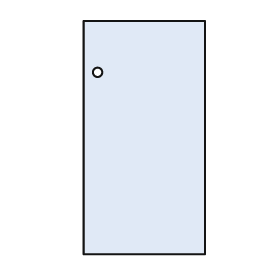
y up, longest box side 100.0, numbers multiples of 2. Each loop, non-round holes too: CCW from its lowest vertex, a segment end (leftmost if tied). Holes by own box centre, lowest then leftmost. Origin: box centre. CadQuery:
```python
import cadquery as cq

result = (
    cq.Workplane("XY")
    .moveTo(-26.0, -50.0)
    .lineTo(26.0, -50.0)
    .lineTo(26.0, 50.0)
    .lineTo(-26.0, 50.0)
    .close()
    .moveTo(-20.0, 28.0)
    .circle(2.0)
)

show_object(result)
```